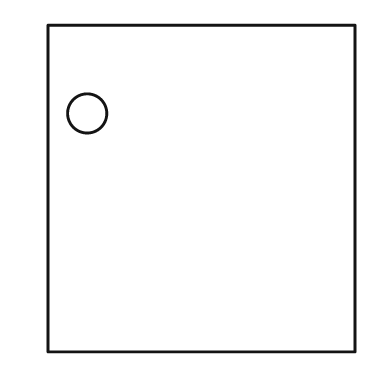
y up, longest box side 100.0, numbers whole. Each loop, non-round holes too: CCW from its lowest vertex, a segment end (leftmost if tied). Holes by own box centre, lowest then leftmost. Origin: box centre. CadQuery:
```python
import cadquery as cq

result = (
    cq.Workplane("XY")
    .moveTo(-47.0, -50.0)
    .lineTo(47.0, -50.0)
    .lineTo(47.0, 50.0)
    .lineTo(-47.0, 50.0)
    .close()
    .moveTo(-35.0, 23.0)
    .circle(6.0)
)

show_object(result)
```